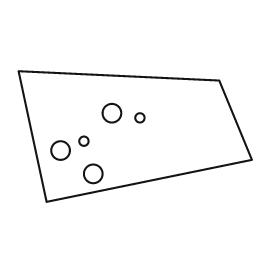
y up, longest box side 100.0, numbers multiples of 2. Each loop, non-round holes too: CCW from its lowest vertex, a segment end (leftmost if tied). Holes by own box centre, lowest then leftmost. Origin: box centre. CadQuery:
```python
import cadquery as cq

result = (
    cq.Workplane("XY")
    .moveTo(-38.0, -28.0)
    .lineTo(50.0, -10.0)
    .lineTo(36.0, 24.0)
    .lineTo(-50.0, 28.0)
    .close()
    .moveTo(-18.0, -16.0)
    .circle(4.0)
    .moveTo(-32.0, -6.0)
    .circle(4.0)
    .moveTo(-22.0, -2.0)
    .circle(2.0)
    .moveTo(2.0, 8.0)
    .circle(2.0)
    .moveTo(-10.0, 10.0)
    .circle(4.0)
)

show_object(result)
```